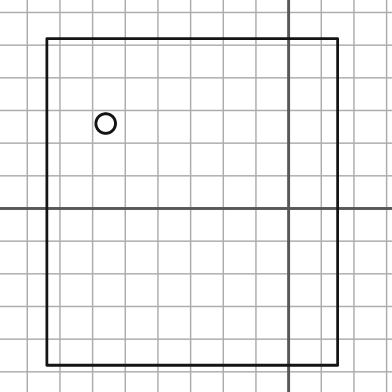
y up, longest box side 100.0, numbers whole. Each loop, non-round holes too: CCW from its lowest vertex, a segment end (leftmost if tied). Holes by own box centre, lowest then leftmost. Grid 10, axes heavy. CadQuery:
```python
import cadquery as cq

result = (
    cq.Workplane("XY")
    .moveTo(-74.0, -48.0)
    .lineTo(15.0, -48.0)
    .lineTo(15.0, 52.0)
    .lineTo(-74.0, 52.0)
    .close()
    .moveTo(-56.0, 26.0)
    .circle(3.0)
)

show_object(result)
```